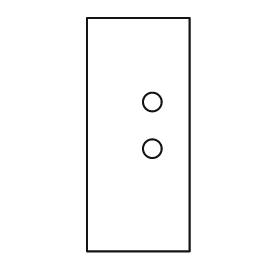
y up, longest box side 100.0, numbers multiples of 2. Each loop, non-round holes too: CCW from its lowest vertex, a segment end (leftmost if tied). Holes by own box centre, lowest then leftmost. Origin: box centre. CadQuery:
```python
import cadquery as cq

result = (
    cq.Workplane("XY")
    .moveTo(-22.0, -50.0)
    .lineTo(22.0, -50.0)
    .lineTo(22.0, 50.0)
    .lineTo(-22.0, 50.0)
    .close()
    .moveTo(6.0, -6.0)
    .circle(4.0)
    .moveTo(6.0, 14.0)
    .circle(4.0)
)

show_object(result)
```